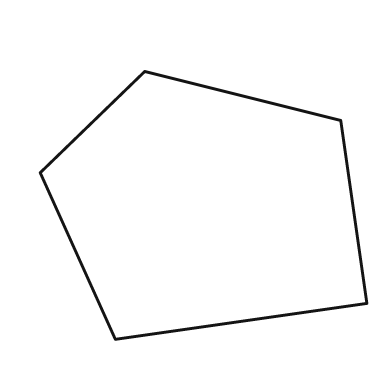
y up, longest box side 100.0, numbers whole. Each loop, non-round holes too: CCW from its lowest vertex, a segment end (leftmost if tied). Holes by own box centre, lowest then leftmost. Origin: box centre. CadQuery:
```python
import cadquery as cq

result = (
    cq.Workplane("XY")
    .moveTo(-27.0, -41.0)
    .lineTo(50.0, -30.0)
    .lineTo(42.0, 26.0)
    .lineTo(-18.0, 41.0)
    .lineTo(-50.0, 10.0)
    .close()
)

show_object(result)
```